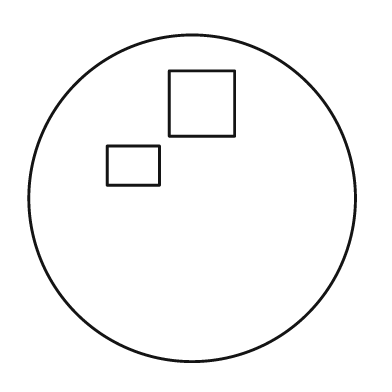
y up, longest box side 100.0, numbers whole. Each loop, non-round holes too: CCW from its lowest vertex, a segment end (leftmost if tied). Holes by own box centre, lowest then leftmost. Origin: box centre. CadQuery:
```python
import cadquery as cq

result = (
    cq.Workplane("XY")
    .moveTo(0.0, 0.0)
    .circle(50.0)
    .moveTo(-26.0, 4.0)
    .lineTo(-10.0, 4.0)
    .lineTo(-10.0, 16.0)
    .lineTo(-26.0, 16.0)
    .close()
    .moveTo(-7.0, 19.0)
    .lineTo(13.0, 19.0)
    .lineTo(13.0, 39.0)
    .lineTo(-7.0, 39.0)
    .close()
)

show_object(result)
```